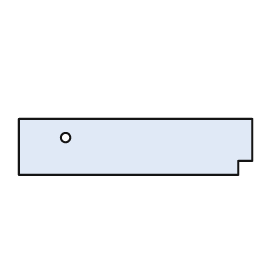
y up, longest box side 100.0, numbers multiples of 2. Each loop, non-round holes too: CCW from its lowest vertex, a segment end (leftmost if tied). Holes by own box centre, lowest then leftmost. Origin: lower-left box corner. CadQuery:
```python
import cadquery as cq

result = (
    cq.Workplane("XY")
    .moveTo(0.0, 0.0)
    .lineTo(94.0, 0.0)
    .lineTo(94.0, 6.0)
    .lineTo(100.0, 6.0)
    .lineTo(100.0, 24.0)
    .lineTo(0.0, 24.0)
    .close()
    .moveTo(20.0, 16.0)
    .circle(2.0)
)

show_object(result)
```